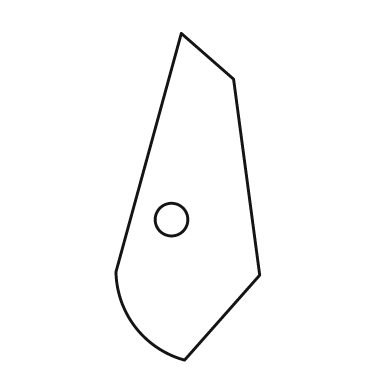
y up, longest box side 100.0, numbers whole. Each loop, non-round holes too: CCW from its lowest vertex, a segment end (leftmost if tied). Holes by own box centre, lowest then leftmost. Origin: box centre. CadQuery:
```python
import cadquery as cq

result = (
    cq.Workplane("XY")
    .moveTo(-1.0, -50.0)
    .lineTo(22.0, -24.0)
    .lineTo(14.0, 36.0)
    .lineTo(-2.0, 50.0)
    .lineTo(-22.0, -23.0)
    .threePointArc((-16.0, -40.0), (-1.0, -50.0))
    .close()
    .moveTo(-5.0, -7.0)
    .circle(5.0)
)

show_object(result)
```